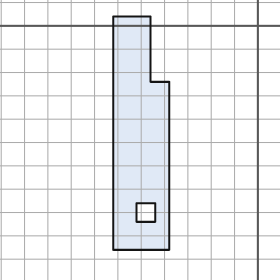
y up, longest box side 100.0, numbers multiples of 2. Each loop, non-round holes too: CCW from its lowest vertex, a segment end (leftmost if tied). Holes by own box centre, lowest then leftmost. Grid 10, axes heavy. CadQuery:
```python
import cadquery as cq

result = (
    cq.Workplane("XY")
    .moveTo(-62.0, -96.0)
    .lineTo(-38.0, -96.0)
    .lineTo(-38.0, -24.0)
    .lineTo(-46.0, -24.0)
    .lineTo(-46.0, 4.0)
    .lineTo(-62.0, 4.0)
    .close()
    .moveTo(-52.0, -84.0)
    .lineTo(-44.0, -84.0)
    .lineTo(-44.0, -76.0)
    .lineTo(-52.0, -76.0)
    .close()
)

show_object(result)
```